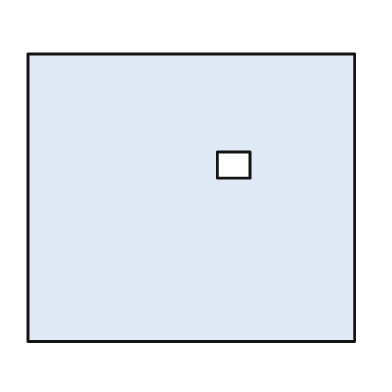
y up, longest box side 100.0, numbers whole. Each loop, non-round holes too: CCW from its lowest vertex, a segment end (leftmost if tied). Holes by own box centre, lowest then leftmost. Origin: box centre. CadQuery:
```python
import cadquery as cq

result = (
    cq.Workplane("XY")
    .moveTo(-50.0, -44.0)
    .lineTo(50.0, -44.0)
    .lineTo(50.0, 44.0)
    .lineTo(-50.0, 44.0)
    .close()
    .moveTo(8.0, 6.0)
    .lineTo(18.0, 6.0)
    .lineTo(18.0, 14.0)
    .lineTo(8.0, 14.0)
    .close()
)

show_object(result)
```